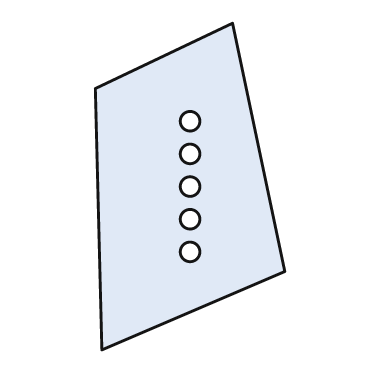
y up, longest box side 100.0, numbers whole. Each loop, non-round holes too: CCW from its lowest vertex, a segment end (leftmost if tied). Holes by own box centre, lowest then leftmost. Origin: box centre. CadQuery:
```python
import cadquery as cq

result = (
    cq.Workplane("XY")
    .moveTo(-27.0, -50.0)
    .lineTo(29.0, -26.0)
    .lineTo(13.0, 50.0)
    .lineTo(-29.0, 30.0)
    .close()
    .moveTo(0.0, -20.0)
    .circle(3.0)
    .moveTo(0.0, -10.0)
    .circle(3.0)
    .moveTo(0.0, 0.0)
    .circle(3.0)
    .moveTo(0.0, 10.0)
    .circle(3.0)
    .moveTo(0.0, 20.0)
    .circle(3.0)
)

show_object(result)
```